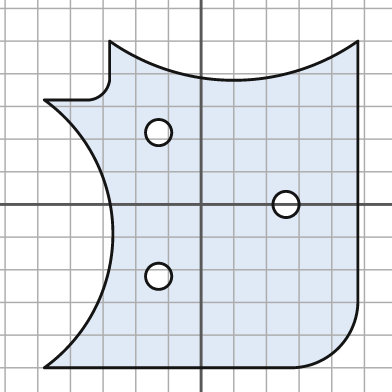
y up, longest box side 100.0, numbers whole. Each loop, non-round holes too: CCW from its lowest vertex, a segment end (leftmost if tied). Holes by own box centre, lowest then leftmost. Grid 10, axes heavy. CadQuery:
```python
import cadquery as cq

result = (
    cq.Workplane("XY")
    .moveTo(-48.0, -50.0)
    .lineTo(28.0, -50.0)
    .threePointArc((42.0, -44.0), (48.0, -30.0))
    .lineTo(48.0, 50.0)
    .threePointArc((10.0, 38.0), (-28.0, 50.0))
    .lineTo(-28.0, 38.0)
    .threePointArc((-30.0, 34.0), (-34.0, 32.0))
    .lineTo(-48.0, 32.0)
    .threePointArc((-27.0, -9.0), (-48.0, -50.0))
    .close()
    .moveTo(-13.0, -22.0)
    .circle(4.0)
    .moveTo(26.0, 0.0)
    .circle(4.0)
    .moveTo(-13.0, 22.0)
    .circle(4.0)
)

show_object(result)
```